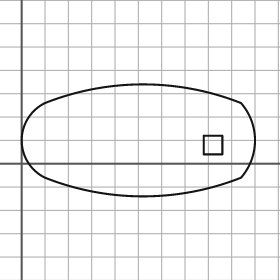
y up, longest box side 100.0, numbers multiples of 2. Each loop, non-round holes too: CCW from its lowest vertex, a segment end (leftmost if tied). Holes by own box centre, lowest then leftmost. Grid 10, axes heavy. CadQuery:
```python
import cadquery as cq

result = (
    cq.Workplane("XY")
    .moveTo(10.0, -6.0)
    .threePointArc((52.0, -14.0), (94.0, -6.0))
    .threePointArc((100.0, 10.0), (94.0, 26.0))
    .threePointArc((52.0, 34.0), (10.0, 26.0))
    .threePointArc((0.0, 10.0), (10.0, -6.0))
    .close()
    .moveTo(78.0, 4.0)
    .lineTo(86.0, 4.0)
    .lineTo(86.0, 12.0)
    .lineTo(78.0, 12.0)
    .close()
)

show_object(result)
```